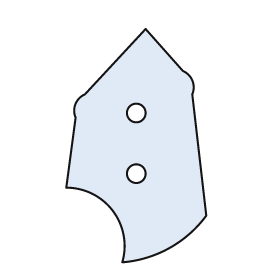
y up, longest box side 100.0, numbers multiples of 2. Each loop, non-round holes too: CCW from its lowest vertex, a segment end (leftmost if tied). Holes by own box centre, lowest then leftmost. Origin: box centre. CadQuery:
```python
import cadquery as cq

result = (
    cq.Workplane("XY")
    .moveTo(-6.0, -50.0)
    .threePointArc((14.0, -44.0), (30.0, -30.0))
    .lineTo(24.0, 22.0)
    .threePointArc((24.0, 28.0), (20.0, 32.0))
    .lineTo(4.0, 50.0)
    .lineTo(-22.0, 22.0)
    .threePointArc((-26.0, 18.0), (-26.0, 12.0))
    .lineTo(-30.0, -18.0)
    .threePointArc((-10.0, -28.0), (-6.0, -50.0))
    .close()
    .moveTo(0.0, -12.0)
    .circle(4.0)
    .moveTo(0.0, 14.0)
    .circle(4.0)
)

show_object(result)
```